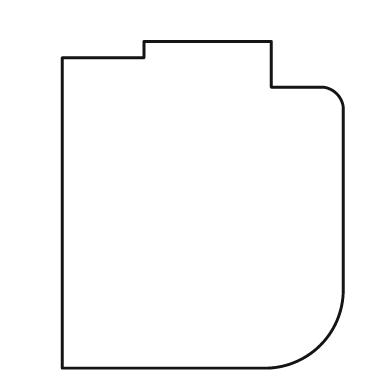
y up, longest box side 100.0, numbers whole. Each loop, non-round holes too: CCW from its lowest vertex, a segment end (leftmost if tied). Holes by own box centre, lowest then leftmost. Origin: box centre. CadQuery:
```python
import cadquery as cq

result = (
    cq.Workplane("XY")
    .moveTo(-43.0, -50.0)
    .lineTo(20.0, -50.0)
    .threePointArc((36.0, -43.0), (43.0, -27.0))
    .lineTo(43.0, 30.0)
    .threePointArc((41.0, 34.0), (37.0, 36.0))
    .lineTo(21.0, 36.0)
    .lineTo(21.0, 50.0)
    .lineTo(-18.0, 50.0)
    .lineTo(-18.0, 45.0)
    .lineTo(-43.0, 45.0)
    .close()
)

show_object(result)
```